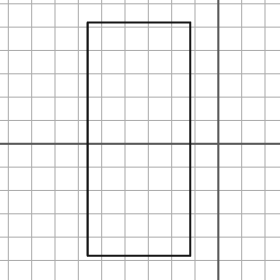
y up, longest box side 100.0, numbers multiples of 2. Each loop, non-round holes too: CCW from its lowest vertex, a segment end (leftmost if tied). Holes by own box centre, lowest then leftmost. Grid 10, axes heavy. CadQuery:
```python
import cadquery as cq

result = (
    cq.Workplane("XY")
    .moveTo(-56.0, -48.0)
    .lineTo(-12.0, -48.0)
    .lineTo(-12.0, 52.0)
    .lineTo(-56.0, 52.0)
    .close()
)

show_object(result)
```